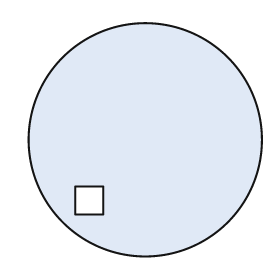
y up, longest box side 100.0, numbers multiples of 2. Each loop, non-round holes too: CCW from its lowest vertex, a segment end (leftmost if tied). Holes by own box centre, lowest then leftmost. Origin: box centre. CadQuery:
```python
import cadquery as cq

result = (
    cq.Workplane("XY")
    .moveTo(0.0, 0.0)
    .circle(50.0)
    .moveTo(-30.0, -32.0)
    .lineTo(-18.0, -32.0)
    .lineTo(-18.0, -20.0)
    .lineTo(-30.0, -20.0)
    .close()
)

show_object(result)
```